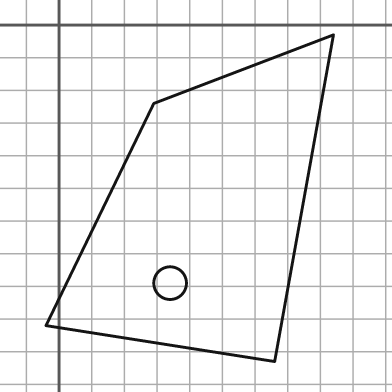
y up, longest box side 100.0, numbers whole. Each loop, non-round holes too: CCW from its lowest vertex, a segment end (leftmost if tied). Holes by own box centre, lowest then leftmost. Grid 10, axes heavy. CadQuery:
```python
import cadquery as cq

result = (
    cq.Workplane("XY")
    .moveTo(66.0, -103.0)
    .lineTo(84.0, -3.0)
    .lineTo(29.0, -24.0)
    .lineTo(-4.0, -92.0)
    .close()
    .moveTo(34.0, -79.0)
    .circle(5.0)
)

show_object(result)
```